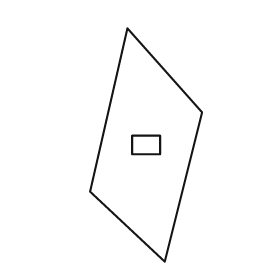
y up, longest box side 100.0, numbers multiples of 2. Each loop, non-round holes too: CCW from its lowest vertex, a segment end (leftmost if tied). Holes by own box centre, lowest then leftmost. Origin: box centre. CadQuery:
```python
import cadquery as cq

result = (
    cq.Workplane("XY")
    .moveTo(8.0, -50.0)
    .lineTo(24.0, 14.0)
    .lineTo(-8.0, 50.0)
    .lineTo(-24.0, -20.0)
    .close()
    .moveTo(-6.0, -4.0)
    .lineTo(6.0, -4.0)
    .lineTo(6.0, 4.0)
    .lineTo(-6.0, 4.0)
    .close()
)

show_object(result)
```